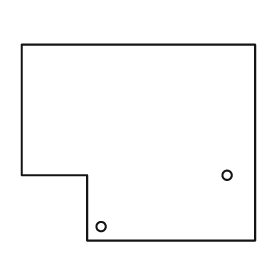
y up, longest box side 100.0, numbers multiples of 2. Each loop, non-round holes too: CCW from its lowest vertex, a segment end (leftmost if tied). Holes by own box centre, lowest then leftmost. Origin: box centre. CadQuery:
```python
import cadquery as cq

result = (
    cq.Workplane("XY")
    .moveTo(-22.0, -42.0)
    .lineTo(50.0, -42.0)
    .lineTo(50.0, 42.0)
    .lineTo(-50.0, 42.0)
    .lineTo(-50.0, -14.0)
    .lineTo(-22.0, -14.0)
    .close()
    .moveTo(-16.0, -36.0)
    .circle(2.0)
    .moveTo(38.0, -14.0)
    .circle(2.0)
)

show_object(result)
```